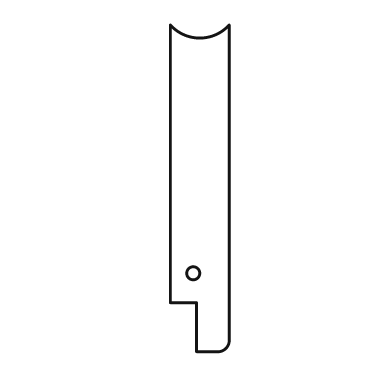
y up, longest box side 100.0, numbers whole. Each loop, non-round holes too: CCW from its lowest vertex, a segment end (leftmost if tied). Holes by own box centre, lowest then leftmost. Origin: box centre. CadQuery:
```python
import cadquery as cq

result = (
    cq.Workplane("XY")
    .moveTo(-1.0, -50.0)
    .lineTo(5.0, -50.0)
    .threePointArc((8.0, -49.0), (9.0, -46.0))
    .lineTo(9.0, 50.0)
    .threePointArc((0.0, 46.0), (-9.0, 50.0))
    .lineTo(-9.0, -35.0)
    .lineTo(-1.0, -35.0)
    .close()
    .moveTo(-2.0, -26.0)
    .circle(2.0)
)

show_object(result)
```